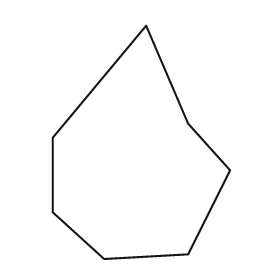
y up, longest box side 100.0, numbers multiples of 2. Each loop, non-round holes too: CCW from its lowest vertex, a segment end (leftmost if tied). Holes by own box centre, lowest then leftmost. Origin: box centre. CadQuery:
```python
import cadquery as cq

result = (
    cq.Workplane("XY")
    .moveTo(-16.0, -50.0)
    .lineTo(20.0, -48.0)
    .lineTo(38.0, -12.0)
    .lineTo(20.0, 8.0)
    .lineTo(2.0, 50.0)
    .lineTo(-38.0, 2.0)
    .lineTo(-38.0, -30.0)
    .close()
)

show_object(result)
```